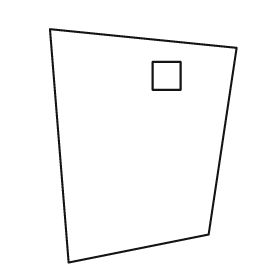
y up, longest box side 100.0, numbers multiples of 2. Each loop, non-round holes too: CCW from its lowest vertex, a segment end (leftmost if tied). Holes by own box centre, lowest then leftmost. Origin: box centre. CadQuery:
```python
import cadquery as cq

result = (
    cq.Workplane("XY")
    .moveTo(-32.0, -50.0)
    .lineTo(28.0, -38.0)
    .lineTo(40.0, 42.0)
    .lineTo(-40.0, 50.0)
    .close()
    .moveTo(4.0, 24.0)
    .lineTo(16.0, 24.0)
    .lineTo(16.0, 36.0)
    .lineTo(4.0, 36.0)
    .close()
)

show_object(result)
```